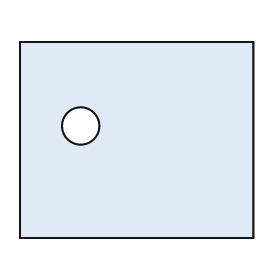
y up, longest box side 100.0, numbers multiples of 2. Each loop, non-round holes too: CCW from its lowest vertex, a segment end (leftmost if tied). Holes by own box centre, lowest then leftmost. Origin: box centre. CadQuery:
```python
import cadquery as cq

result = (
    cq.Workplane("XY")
    .moveTo(-50.0, -42.0)
    .lineTo(50.0, -42.0)
    .lineTo(50.0, 42.0)
    .lineTo(-50.0, 42.0)
    .close()
    .moveTo(-24.0, 6.0)
    .circle(8.0)
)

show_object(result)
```